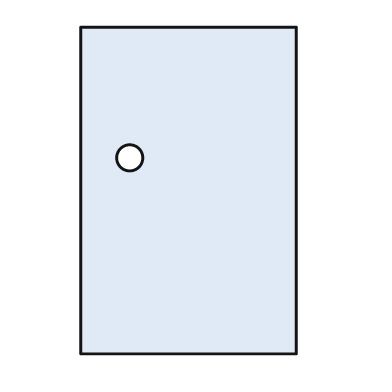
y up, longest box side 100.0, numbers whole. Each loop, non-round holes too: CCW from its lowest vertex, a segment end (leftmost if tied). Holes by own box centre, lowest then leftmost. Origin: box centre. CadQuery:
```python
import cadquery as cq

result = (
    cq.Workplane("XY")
    .moveTo(-33.0, -50.0)
    .lineTo(33.0, -50.0)
    .lineTo(33.0, 50.0)
    .lineTo(-33.0, 50.0)
    .close()
    .moveTo(-18.0, 10.0)
    .circle(4.0)
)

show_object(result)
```